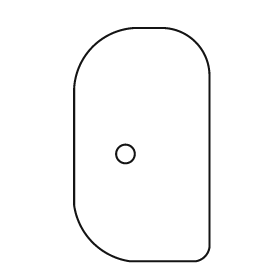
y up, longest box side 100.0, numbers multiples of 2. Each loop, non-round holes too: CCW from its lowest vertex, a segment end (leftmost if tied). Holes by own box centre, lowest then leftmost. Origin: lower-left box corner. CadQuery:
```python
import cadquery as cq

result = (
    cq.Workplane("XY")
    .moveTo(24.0, 0.0)
    .lineTo(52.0, 0.0)
    .threePointArc((56.0, 2.0), (58.0, 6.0))
    .lineTo(58.0, 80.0)
    .threePointArc((52.0, 94.0), (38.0, 100.0))
    .lineTo(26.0, 100.0)
    .threePointArc((8.0, 92.0), (0.0, 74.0))
    .lineTo(0.0, 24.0)
    .threePointArc((8.0, 8.0), (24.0, 0.0))
    .close()
    .moveTo(22.0, 46.0)
    .circle(4.0)
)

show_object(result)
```